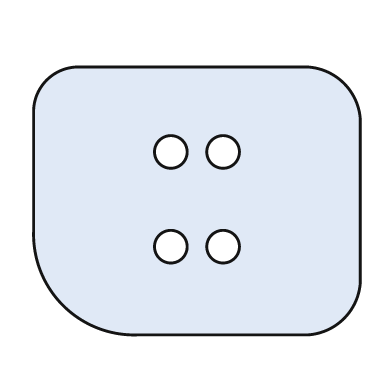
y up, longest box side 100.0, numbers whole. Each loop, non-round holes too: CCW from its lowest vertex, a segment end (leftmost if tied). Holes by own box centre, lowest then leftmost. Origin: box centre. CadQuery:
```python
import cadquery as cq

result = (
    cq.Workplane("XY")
    .moveTo(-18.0, -41.0)
    .lineTo(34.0, -41.0)
    .threePointArc((45.0, -36.0), (50.0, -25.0))
    .lineTo(50.0, 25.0)
    .threePointArc((45.0, 36.0), (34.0, 41.0))
    .lineTo(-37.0, 41.0)
    .threePointArc((-46.0, 37.0), (-50.0, 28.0))
    .lineTo(-50.0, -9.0)
    .threePointArc((-41.0, -32.0), (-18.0, -41.0))
    .close()
    .moveTo(-8.0, -14.0)
    .circle(5.0)
    .moveTo(8.0, -14.0)
    .circle(5.0)
    .moveTo(-8.0, 15.0)
    .circle(5.0)
    .moveTo(8.0, 15.0)
    .circle(5.0)
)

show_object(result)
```